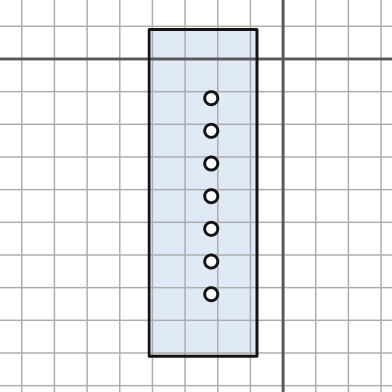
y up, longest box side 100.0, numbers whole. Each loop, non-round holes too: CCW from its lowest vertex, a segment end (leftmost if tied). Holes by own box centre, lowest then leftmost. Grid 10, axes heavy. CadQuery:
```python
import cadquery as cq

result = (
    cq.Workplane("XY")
    .moveTo(-41.0, -91.0)
    .lineTo(-8.0, -91.0)
    .lineTo(-8.0, 9.0)
    .lineTo(-41.0, 9.0)
    .close()
    .moveTo(-22.0, -72.0)
    .circle(2.0)
    .moveTo(-22.0, -62.0)
    .circle(2.0)
    .moveTo(-22.0, -52.0)
    .circle(2.0)
    .moveTo(-22.0, -42.0)
    .circle(2.0)
    .moveTo(-22.0, -32.0)
    .circle(2.0)
    .moveTo(-22.0, -22.0)
    .circle(2.0)
    .moveTo(-22.0, -12.0)
    .circle(2.0)
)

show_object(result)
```